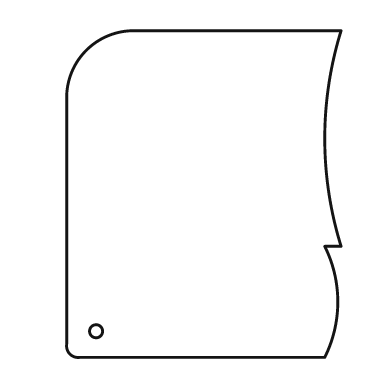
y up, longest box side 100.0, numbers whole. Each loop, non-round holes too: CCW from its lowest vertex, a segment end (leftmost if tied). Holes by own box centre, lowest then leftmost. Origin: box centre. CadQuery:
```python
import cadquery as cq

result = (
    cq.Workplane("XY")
    .moveTo(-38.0, -50.0)
    .lineTo(37.0, -50.0)
    .threePointArc((41.0, -33.0), (37.0, -16.0))
    .lineTo(42.0, -16.0)
    .threePointArc((37.0, 17.0), (42.0, 50.0))
    .lineTo(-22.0, 50.0)
    .threePointArc((-36.0, 44.0), (-42.0, 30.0))
    .lineTo(-42.0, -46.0)
    .threePointArc((-41.0, -49.0), (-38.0, -50.0))
    .close()
    .moveTo(-33.0, -42.0)
    .circle(2.0)
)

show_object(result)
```